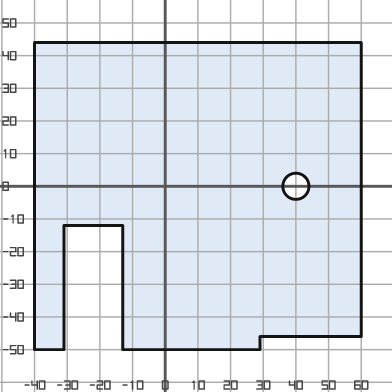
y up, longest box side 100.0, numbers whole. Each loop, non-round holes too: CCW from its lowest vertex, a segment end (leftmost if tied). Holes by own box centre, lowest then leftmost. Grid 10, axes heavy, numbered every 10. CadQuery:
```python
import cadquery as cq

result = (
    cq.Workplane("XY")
    .moveTo(-40.0, -50.0)
    .lineTo(-31.0, -50.0)
    .lineTo(-31.0, -12.0)
    .lineTo(-13.0, -12.0)
    .lineTo(-13.0, -50.0)
    .lineTo(29.0, -50.0)
    .lineTo(29.0, -46.0)
    .lineTo(60.0, -46.0)
    .lineTo(60.0, 44.0)
    .lineTo(-40.0, 44.0)
    .close()
    .moveTo(40.0, 0.0)
    .circle(4.0)
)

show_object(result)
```